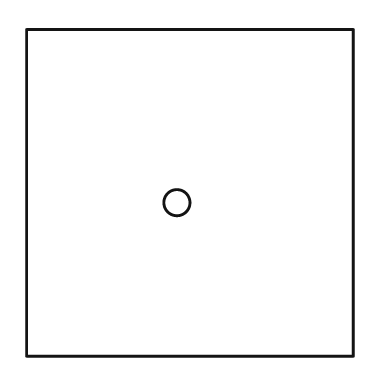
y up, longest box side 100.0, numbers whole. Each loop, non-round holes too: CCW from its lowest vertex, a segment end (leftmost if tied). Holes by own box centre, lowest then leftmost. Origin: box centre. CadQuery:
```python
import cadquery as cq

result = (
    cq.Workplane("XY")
    .moveTo(-50.0, -50.0)
    .lineTo(50.0, -50.0)
    .lineTo(50.0, 50.0)
    .lineTo(-50.0, 50.0)
    .close()
    .moveTo(-4.0, -3.0)
    .circle(4.0)
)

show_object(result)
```